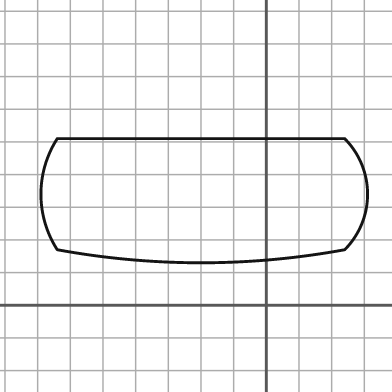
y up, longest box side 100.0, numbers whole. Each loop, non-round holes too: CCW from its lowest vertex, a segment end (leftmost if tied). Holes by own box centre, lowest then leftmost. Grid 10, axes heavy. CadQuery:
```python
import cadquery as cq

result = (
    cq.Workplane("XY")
    .moveTo(-64.0, 17.0)
    .threePointArc((-20.0, 13.0), (24.0, 17.0))
    .threePointArc((31.0, 34.0), (24.0, 51.0))
    .lineTo(-64.0, 51.0)
    .threePointArc((-69.0, 34.0), (-64.0, 17.0))
    .close()
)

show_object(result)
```